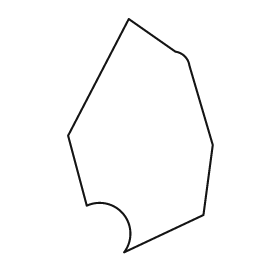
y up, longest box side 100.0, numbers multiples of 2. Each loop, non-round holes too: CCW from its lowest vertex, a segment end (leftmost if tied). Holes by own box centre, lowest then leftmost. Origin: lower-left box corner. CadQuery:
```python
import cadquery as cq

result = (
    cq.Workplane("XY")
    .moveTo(24.0, 0.0)
    .lineTo(58.0, 16.0)
    .lineTo(62.0, 46.0)
    .lineTo(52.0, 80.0)
    .threePointArc((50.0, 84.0), (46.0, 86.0))
    .lineTo(26.0, 100.0)
    .lineTo(0.0, 50.0)
    .lineTo(8.0, 20.0)
    .threePointArc((24.0, 16.0), (24.0, 0.0))
    .close()
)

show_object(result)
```